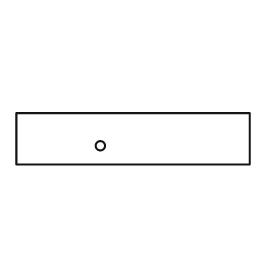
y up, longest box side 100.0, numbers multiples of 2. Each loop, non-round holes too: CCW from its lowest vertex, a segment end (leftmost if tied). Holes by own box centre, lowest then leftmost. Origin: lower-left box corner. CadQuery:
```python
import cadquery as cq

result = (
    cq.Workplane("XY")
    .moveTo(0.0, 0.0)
    .lineTo(100.0, 0.0)
    .lineTo(100.0, 22.0)
    .lineTo(0.0, 22.0)
    .close()
    .moveTo(36.0, 8.0)
    .circle(2.0)
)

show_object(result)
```